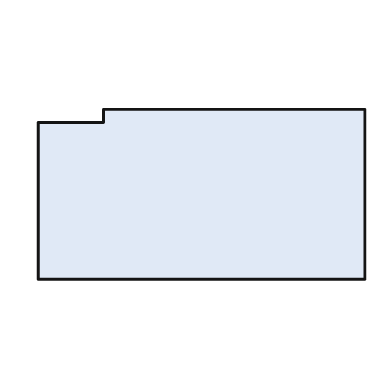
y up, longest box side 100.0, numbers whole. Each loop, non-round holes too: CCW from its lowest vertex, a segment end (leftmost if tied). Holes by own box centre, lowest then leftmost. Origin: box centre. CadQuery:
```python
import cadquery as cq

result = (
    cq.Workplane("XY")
    .moveTo(-50.0, -26.0)
    .lineTo(50.0, -26.0)
    .lineTo(50.0, 26.0)
    .lineTo(-30.0, 26.0)
    .lineTo(-30.0, 22.0)
    .lineTo(-50.0, 22.0)
    .close()
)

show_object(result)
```